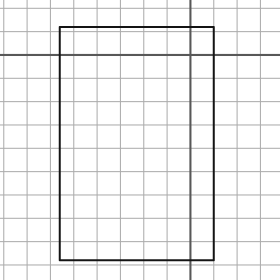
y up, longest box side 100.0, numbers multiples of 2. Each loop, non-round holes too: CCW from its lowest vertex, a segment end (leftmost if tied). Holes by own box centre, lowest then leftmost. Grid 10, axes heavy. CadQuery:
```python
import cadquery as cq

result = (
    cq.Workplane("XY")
    .moveTo(-56.0, -88.0)
    .lineTo(10.0, -88.0)
    .lineTo(10.0, 12.0)
    .lineTo(-56.0, 12.0)
    .close()
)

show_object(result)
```